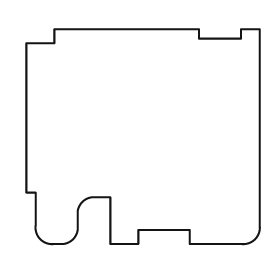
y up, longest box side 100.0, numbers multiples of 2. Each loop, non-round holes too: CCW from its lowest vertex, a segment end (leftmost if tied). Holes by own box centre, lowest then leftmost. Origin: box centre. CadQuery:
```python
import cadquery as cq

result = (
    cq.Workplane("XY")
    .moveTo(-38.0, -46.0)
    .lineTo(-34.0, -46.0)
    .threePointArc((-30.0, -44.0), (-28.0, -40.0))
    .lineTo(-28.0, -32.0)
    .threePointArc((-26.0, -28.0), (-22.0, -26.0))
    .lineTo(-14.0, -26.0)
    .lineTo(-14.0, -46.0)
    .lineTo(-2.0, -46.0)
    .lineTo(-2.0, -40.0)
    .lineTo(20.0, -40.0)
    .lineTo(20.0, -46.0)
    .lineTo(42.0, -46.0)
    .threePointArc((48.0, -44.0), (50.0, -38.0))
    .lineTo(50.0, 46.0)
    .lineTo(42.0, 46.0)
    .lineTo(42.0, 42.0)
    .lineTo(24.0, 42.0)
    .lineTo(24.0, 46.0)
    .lineTo(-38.0, 46.0)
    .lineTo(-38.0, 40.0)
    .lineTo(-50.0, 40.0)
    .lineTo(-50.0, -24.0)
    .lineTo(-46.0, -24.0)
    .lineTo(-46.0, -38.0)
    .threePointArc((-44.0, -44.0), (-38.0, -46.0))
    .close()
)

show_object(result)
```